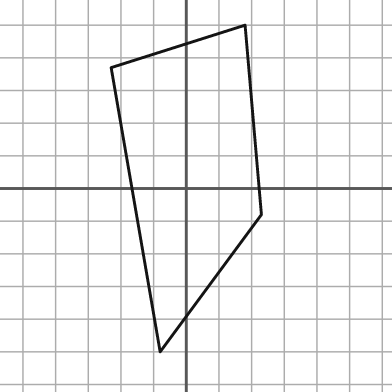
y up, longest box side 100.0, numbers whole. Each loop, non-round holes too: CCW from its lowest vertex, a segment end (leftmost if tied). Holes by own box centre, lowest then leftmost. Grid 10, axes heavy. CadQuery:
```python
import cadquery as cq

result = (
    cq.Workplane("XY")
    .moveTo(-8.0, -50.0)
    .lineTo(23.0, -8.0)
    .lineTo(18.0, 50.0)
    .lineTo(-23.0, 37.0)
    .close()
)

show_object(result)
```